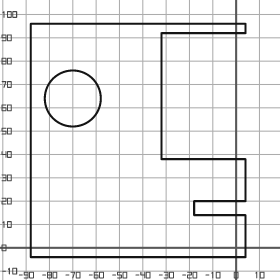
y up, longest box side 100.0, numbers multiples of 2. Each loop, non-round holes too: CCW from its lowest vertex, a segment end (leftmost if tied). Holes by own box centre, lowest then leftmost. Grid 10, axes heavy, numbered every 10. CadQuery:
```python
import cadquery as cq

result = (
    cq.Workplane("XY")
    .moveTo(-88.0, -4.0)
    .lineTo(4.0, -4.0)
    .lineTo(4.0, 14.0)
    .lineTo(-18.0, 14.0)
    .lineTo(-18.0, 20.0)
    .lineTo(4.0, 20.0)
    .lineTo(4.0, 38.0)
    .lineTo(-32.0, 38.0)
    .lineTo(-32.0, 92.0)
    .lineTo(4.0, 92.0)
    .lineTo(4.0, 96.0)
    .lineTo(-88.0, 96.0)
    .close()
    .moveTo(-70.0, 64.0)
    .circle(12.0)
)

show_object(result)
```